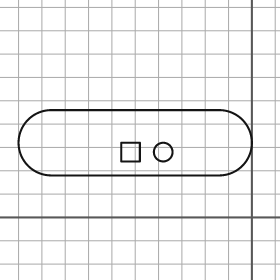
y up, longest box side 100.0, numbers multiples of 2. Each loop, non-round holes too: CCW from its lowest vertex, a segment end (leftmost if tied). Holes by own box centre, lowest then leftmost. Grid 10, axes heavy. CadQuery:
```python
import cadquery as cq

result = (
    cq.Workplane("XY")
    .moveTo(-86.0, 18.0)
    .lineTo(-14.0, 18.0)
    .threePointArc((0.0, 32.0), (-14.0, 46.0))
    .lineTo(-86.0, 46.0)
    .threePointArc((-100.0, 32.0), (-86.0, 18.0))
    .close()
    .moveTo(-56.0, 24.0)
    .lineTo(-48.0, 24.0)
    .lineTo(-48.0, 32.0)
    .lineTo(-56.0, 32.0)
    .close()
    .moveTo(-38.0, 28.0)
    .circle(4.0)
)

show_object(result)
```